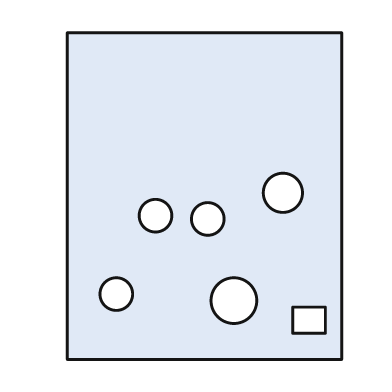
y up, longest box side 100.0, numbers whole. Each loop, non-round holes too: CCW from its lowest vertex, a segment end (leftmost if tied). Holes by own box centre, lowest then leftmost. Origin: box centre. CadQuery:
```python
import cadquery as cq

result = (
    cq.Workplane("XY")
    .moveTo(-42.0, -50.0)
    .lineTo(42.0, -50.0)
    .lineTo(42.0, 50.0)
    .lineTo(-42.0, 50.0)
    .close()
    .moveTo(27.0, -42.0)
    .lineTo(37.0, -42.0)
    .lineTo(37.0, -34.0)
    .lineTo(27.0, -34.0)
    .close()
    .moveTo(9.0, -32.0)
    .circle(7.0)
    .moveTo(-27.0, -30.0)
    .circle(5.0)
    .moveTo(1.0, -7.0)
    .circle(5.0)
    .moveTo(-15.0, -6.0)
    .circle(5.0)
    .moveTo(24.0, 1.0)
    .circle(6.0)
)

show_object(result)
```